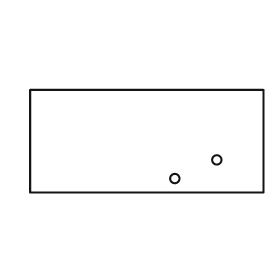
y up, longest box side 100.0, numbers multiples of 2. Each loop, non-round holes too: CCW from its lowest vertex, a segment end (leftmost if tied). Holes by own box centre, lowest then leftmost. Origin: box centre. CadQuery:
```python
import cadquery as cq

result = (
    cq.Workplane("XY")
    .moveTo(-50.0, -22.0)
    .lineTo(50.0, -22.0)
    .lineTo(50.0, 22.0)
    .lineTo(-50.0, 22.0)
    .close()
    .moveTo(12.0, -16.0)
    .circle(2.0)
    .moveTo(30.0, -8.0)
    .circle(2.0)
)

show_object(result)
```